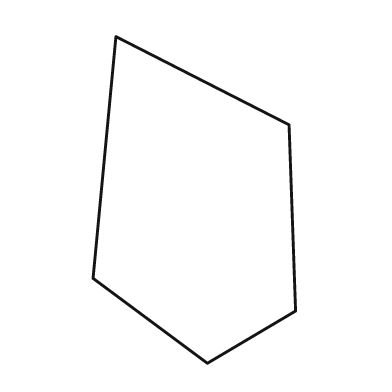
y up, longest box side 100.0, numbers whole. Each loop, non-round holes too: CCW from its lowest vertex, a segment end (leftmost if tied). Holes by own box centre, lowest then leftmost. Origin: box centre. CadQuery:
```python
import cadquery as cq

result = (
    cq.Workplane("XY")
    .moveTo(4.0, -50.0)
    .lineTo(31.0, -34.0)
    .lineTo(29.0, 23.0)
    .lineTo(-24.0, 50.0)
    .lineTo(-31.0, -24.0)
    .close()
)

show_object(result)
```